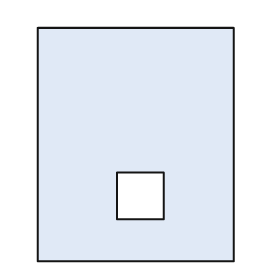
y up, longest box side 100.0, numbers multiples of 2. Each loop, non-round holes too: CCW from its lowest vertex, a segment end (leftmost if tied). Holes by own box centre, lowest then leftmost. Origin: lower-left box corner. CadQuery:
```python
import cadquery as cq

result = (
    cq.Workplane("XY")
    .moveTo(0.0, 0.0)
    .lineTo(84.0, 0.0)
    .lineTo(84.0, 100.0)
    .lineTo(0.0, 100.0)
    .close()
    .moveTo(34.0, 18.0)
    .lineTo(54.0, 18.0)
    .lineTo(54.0, 38.0)
    .lineTo(34.0, 38.0)
    .close()
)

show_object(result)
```